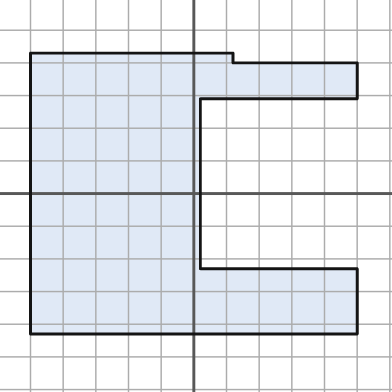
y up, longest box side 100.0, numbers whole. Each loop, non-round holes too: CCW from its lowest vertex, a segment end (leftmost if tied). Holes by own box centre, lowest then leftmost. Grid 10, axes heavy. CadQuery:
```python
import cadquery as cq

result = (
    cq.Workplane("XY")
    .moveTo(-50.0, -43.0)
    .lineTo(50.0, -43.0)
    .lineTo(50.0, -23.0)
    .lineTo(2.0, -23.0)
    .lineTo(2.0, 29.0)
    .lineTo(50.0, 29.0)
    .lineTo(50.0, 40.0)
    .lineTo(12.0, 40.0)
    .lineTo(12.0, 43.0)
    .lineTo(-50.0, 43.0)
    .close()
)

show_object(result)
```